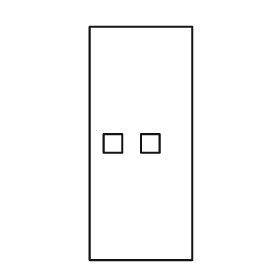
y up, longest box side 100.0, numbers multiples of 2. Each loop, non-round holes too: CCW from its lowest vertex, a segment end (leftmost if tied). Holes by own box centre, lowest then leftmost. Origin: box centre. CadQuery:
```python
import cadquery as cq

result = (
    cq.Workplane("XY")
    .moveTo(-22.0, -50.0)
    .lineTo(22.0, -50.0)
    .lineTo(22.0, 50.0)
    .lineTo(-22.0, 50.0)
    .close()
    .moveTo(-16.0, -4.0)
    .lineTo(-8.0, -4.0)
    .lineTo(-8.0, 4.0)
    .lineTo(-16.0, 4.0)
    .close()
    .moveTo(0.0, -4.0)
    .lineTo(8.0, -4.0)
    .lineTo(8.0, 4.0)
    .lineTo(0.0, 4.0)
    .close()
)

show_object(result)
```